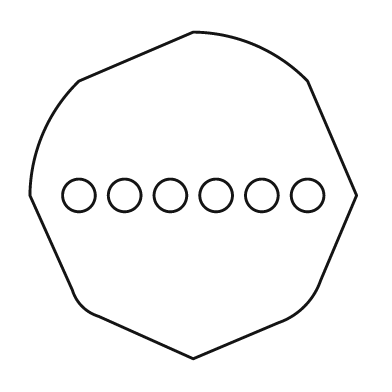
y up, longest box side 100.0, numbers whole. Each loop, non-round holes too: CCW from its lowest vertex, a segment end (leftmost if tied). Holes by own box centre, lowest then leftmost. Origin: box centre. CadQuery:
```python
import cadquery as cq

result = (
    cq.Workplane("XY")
    .moveTo(0.0, -50.0)
    .lineTo(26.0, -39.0)
    .threePointArc((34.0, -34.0), (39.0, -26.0))
    .lineTo(50.0, 0.0)
    .lineTo(35.0, 35.0)
    .threePointArc((19.0, 46.0), (0.0, 50.0))
    .lineTo(-35.0, 35.0)
    .threePointArc((-46.0, 19.0), (-50.0, 0.0))
    .lineTo(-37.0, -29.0)
    .threePointArc((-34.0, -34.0), (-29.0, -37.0))
    .close()
    .moveTo(-35.0, 0.0)
    .circle(5.0)
    .moveTo(-21.0, 0.0)
    .circle(5.0)
    .moveTo(-7.0, 0.0)
    .circle(5.0)
    .moveTo(7.0, 0.0)
    .circle(5.0)
    .moveTo(21.0, 0.0)
    .circle(5.0)
    .moveTo(35.0, 0.0)
    .circle(5.0)
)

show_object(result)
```